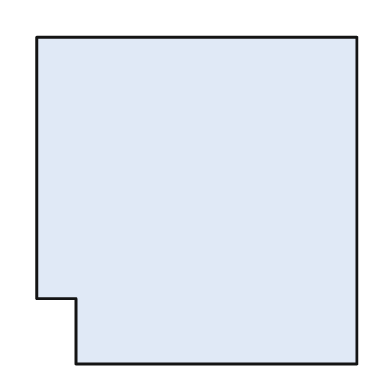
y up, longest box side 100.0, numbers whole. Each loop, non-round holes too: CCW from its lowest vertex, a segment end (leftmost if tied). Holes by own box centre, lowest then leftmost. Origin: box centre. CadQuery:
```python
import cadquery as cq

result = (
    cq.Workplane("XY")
    .moveTo(-37.0, -50.0)
    .lineTo(49.0, -50.0)
    .lineTo(49.0, 50.0)
    .lineTo(-49.0, 50.0)
    .lineTo(-49.0, -30.0)
    .lineTo(-37.0, -30.0)
    .close()
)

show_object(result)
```